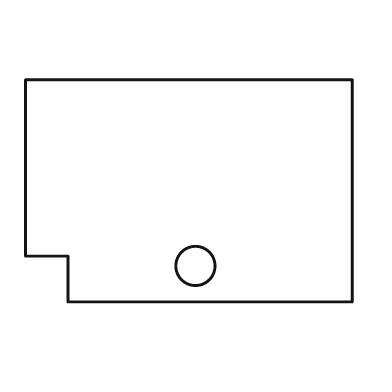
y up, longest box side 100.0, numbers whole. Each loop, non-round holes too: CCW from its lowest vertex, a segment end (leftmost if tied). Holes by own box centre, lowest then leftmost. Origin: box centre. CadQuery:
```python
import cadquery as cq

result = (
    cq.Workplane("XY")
    .moveTo(-37.0, -34.0)
    .lineTo(50.0, -34.0)
    .lineTo(50.0, 34.0)
    .lineTo(-50.0, 34.0)
    .lineTo(-50.0, -20.0)
    .lineTo(-37.0, -20.0)
    .close()
    .moveTo(2.0, -23.0)
    .circle(6.0)
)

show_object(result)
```